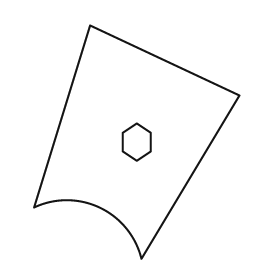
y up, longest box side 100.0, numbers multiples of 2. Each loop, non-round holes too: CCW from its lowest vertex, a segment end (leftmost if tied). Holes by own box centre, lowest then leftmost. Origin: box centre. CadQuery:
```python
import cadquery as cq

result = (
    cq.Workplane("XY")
    .moveTo(2.0, -50.0)
    .lineTo(44.0, 20.0)
    .lineTo(-20.0, 50.0)
    .lineTo(-44.0, -28.0)
    .threePointArc((-16.0, -28.0), (2.0, -50.0))
    .close()
    .moveTo(0.0, -8.0)
    .lineTo(6.0, -4.0)
    .lineTo(6.0, 4.0)
    .lineTo(0.0, 8.0)
    .lineTo(-6.0, 4.0)
    .lineTo(-6.0, -4.0)
    .close()
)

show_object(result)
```